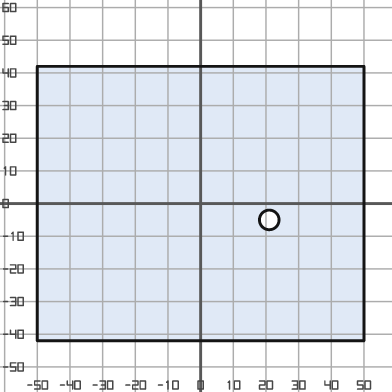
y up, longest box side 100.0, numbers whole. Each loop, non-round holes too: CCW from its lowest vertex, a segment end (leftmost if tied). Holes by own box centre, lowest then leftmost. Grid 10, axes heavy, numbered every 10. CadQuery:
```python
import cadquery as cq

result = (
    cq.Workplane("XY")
    .moveTo(-50.0, -42.0)
    .lineTo(50.0, -42.0)
    .lineTo(50.0, 42.0)
    .lineTo(-50.0, 42.0)
    .close()
    .moveTo(21.0, -5.0)
    .circle(3.0)
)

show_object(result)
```